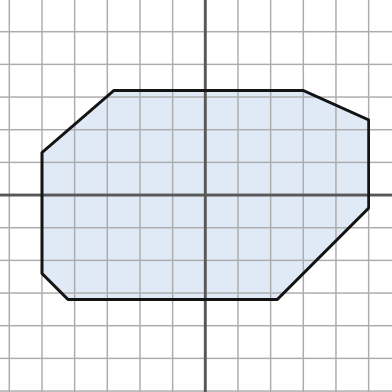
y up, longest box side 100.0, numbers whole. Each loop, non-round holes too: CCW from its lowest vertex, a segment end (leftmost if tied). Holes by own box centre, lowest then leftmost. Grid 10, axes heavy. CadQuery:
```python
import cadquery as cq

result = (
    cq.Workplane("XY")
    .moveTo(-42.0, -32.0)
    .lineTo(22.0, -32.0)
    .lineTo(50.0, -4.0)
    .lineTo(50.0, 23.0)
    .lineTo(30.0, 32.0)
    .lineTo(-28.0, 32.0)
    .lineTo(-50.0, 13.0)
    .lineTo(-50.0, -24.0)
    .close()
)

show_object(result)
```